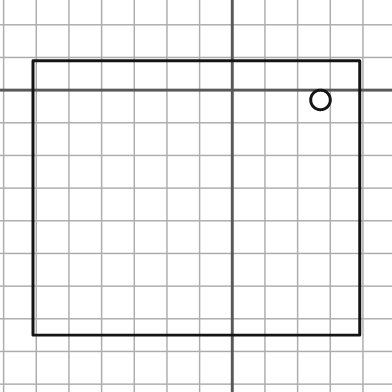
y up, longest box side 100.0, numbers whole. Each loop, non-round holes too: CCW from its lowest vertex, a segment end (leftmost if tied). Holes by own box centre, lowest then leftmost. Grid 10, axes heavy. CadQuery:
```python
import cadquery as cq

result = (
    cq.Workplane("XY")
    .moveTo(-61.0, -75.0)
    .lineTo(39.0, -75.0)
    .lineTo(39.0, 9.0)
    .lineTo(-61.0, 9.0)
    .close()
    .moveTo(27.0, -3.0)
    .circle(3.0)
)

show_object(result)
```